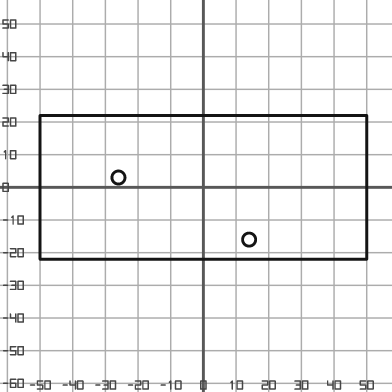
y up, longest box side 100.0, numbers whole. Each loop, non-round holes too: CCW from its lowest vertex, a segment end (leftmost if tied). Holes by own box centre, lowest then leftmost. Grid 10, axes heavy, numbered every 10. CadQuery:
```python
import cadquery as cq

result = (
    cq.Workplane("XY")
    .moveTo(-50.0, -22.0)
    .lineTo(50.0, -22.0)
    .lineTo(50.0, 22.0)
    .lineTo(-50.0, 22.0)
    .close()
    .moveTo(14.0, -16.0)
    .circle(2.0)
    .moveTo(-26.0, 3.0)
    .circle(2.0)
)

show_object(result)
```